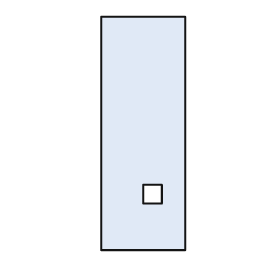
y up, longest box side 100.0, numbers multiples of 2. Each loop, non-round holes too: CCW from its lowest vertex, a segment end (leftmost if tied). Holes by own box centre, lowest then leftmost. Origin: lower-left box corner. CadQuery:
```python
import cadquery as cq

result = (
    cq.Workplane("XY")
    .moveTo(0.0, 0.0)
    .lineTo(36.0, 0.0)
    .lineTo(36.0, 100.0)
    .lineTo(0.0, 100.0)
    .close()
    .moveTo(18.0, 20.0)
    .lineTo(26.0, 20.0)
    .lineTo(26.0, 28.0)
    .lineTo(18.0, 28.0)
    .close()
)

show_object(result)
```